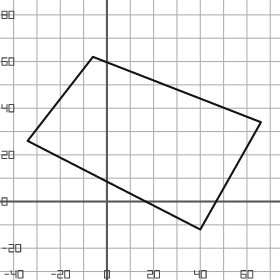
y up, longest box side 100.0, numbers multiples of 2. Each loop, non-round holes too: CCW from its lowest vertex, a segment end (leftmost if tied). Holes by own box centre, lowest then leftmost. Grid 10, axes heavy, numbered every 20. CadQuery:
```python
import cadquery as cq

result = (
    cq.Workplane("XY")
    .moveTo(40.0, -12.0)
    .lineTo(66.0, 34.0)
    .lineTo(-6.0, 62.0)
    .lineTo(-34.0, 26.0)
    .close()
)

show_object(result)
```